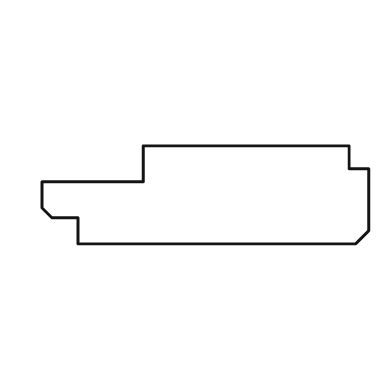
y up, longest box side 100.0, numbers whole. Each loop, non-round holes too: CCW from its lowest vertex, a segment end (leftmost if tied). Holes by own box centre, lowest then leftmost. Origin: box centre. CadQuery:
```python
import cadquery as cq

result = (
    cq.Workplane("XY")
    .moveTo(-39.0, -15.0)
    .lineTo(46.0, -15.0)
    .lineTo(50.0, -11.0)
    .lineTo(50.0, 8.0)
    .lineTo(44.0, 8.0)
    .lineTo(44.0, 15.0)
    .lineTo(-19.0, 15.0)
    .lineTo(-19.0, 4.0)
    .lineTo(-50.0, 4.0)
    .lineTo(-50.0, -4.0)
    .lineTo(-47.0, -7.0)
    .lineTo(-39.0, -7.0)
    .close()
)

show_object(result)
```